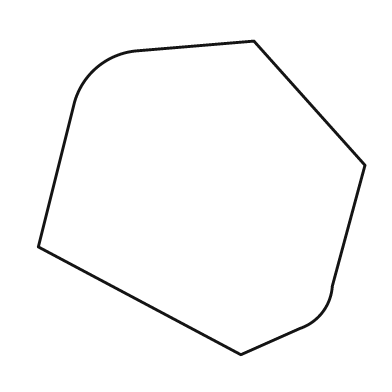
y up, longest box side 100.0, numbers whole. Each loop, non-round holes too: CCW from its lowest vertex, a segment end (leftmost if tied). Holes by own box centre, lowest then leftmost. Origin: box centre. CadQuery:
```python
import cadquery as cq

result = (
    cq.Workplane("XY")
    .moveTo(12.0, -48.0)
    .lineTo(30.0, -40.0)
    .threePointArc((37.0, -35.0), (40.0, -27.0))
    .lineTo(50.0, 10.0)
    .lineTo(16.0, 48.0)
    .lineTo(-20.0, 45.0)
    .threePointArc((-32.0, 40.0), (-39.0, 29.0))
    .lineTo(-50.0, -15.0)
    .close()
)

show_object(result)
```